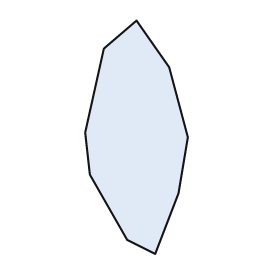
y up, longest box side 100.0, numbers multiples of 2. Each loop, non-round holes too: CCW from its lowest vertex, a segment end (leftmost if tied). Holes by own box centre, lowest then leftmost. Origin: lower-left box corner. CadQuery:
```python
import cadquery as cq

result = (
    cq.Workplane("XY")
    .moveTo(30.0, 0.0)
    .lineTo(40.0, 26.0)
    .lineTo(44.0, 50.0)
    .lineTo(36.0, 80.0)
    .lineTo(22.0, 100.0)
    .lineTo(8.0, 88.0)
    .lineTo(0.0, 52.0)
    .lineTo(2.0, 34.0)
    .lineTo(18.0, 6.0)
    .close()
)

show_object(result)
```